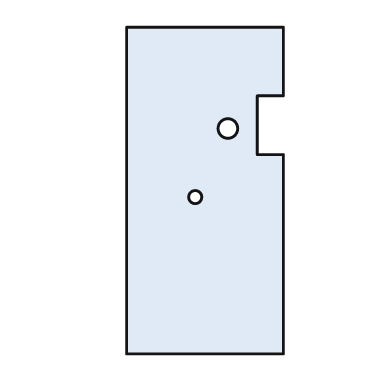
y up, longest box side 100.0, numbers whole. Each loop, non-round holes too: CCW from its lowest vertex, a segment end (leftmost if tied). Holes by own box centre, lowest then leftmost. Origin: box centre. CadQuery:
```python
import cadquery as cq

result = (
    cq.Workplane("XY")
    .moveTo(-24.0, -50.0)
    .lineTo(24.0, -50.0)
    .lineTo(24.0, 11.0)
    .lineTo(16.0, 11.0)
    .lineTo(16.0, 29.0)
    .lineTo(24.0, 29.0)
    .lineTo(24.0, 50.0)
    .lineTo(-24.0, 50.0)
    .close()
    .moveTo(-3.0, -2.0)
    .circle(2.0)
    .moveTo(7.0, 19.0)
    .circle(3.0)
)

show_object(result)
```